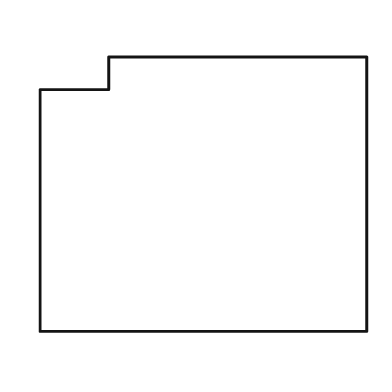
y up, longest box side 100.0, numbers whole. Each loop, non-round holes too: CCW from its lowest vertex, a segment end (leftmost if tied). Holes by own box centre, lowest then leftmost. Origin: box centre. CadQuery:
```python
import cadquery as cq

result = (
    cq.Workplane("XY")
    .moveTo(-50.0, -42.0)
    .lineTo(50.0, -42.0)
    .lineTo(50.0, 42.0)
    .lineTo(-29.0, 42.0)
    .lineTo(-29.0, 32.0)
    .lineTo(-50.0, 32.0)
    .close()
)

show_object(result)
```